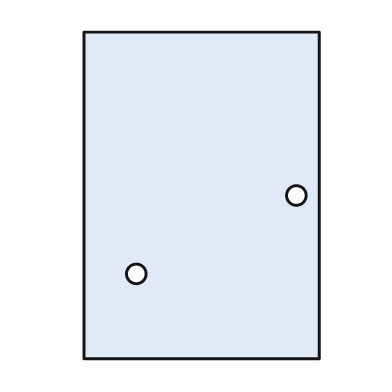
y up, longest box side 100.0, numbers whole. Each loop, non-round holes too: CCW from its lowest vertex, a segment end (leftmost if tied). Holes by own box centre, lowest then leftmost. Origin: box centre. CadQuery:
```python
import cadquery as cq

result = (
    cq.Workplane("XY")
    .moveTo(-36.0, -50.0)
    .lineTo(36.0, -50.0)
    .lineTo(36.0, 50.0)
    .lineTo(-36.0, 50.0)
    .close()
    .moveTo(-20.0, -24.0)
    .circle(3.0)
    .moveTo(29.0, 0.0)
    .circle(3.0)
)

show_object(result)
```